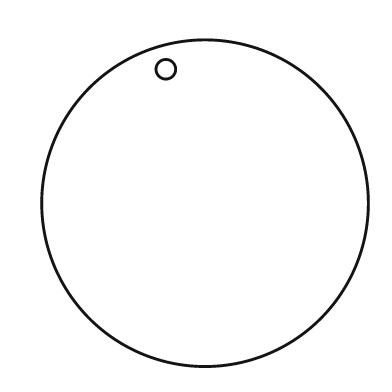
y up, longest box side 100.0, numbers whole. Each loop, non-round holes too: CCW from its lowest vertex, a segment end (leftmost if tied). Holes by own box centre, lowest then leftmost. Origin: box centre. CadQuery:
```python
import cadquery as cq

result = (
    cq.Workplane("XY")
    .moveTo(0.0, 0.0)
    .circle(50.0)
    .moveTo(-12.0, 41.0)
    .circle(3.0)
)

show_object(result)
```